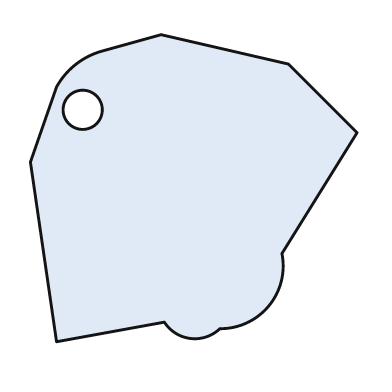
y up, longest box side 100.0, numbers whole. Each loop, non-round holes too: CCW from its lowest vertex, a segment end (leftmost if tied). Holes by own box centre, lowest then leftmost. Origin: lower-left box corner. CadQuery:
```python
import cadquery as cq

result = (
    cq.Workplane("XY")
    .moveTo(8.0, 0.0)
    .lineTo(41.0, 6.0)
    .threePointArc((49.0, 1.0), (58.0, 4.0))
    .threePointArc((73.0, 11.0), (77.0, 27.0))
    .lineTo(100.0, 64.0)
    .lineTo(79.0, 85.0)
    .lineTo(40.0, 94.0)
    .lineTo(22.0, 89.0)
    .threePointArc((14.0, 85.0), (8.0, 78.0))
    .lineTo(0.0, 55.0)
    .close()
    .moveTo(16.0, 71.0)
    .circle(6.0)
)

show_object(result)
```